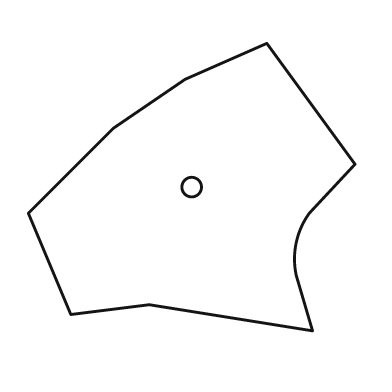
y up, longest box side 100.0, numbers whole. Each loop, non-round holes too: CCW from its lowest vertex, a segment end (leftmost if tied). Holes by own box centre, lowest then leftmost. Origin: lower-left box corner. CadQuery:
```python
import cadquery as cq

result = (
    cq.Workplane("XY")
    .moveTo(87.0, 0.0)
    .lineTo(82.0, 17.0)
    .threePointArc((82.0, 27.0), (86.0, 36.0))
    .lineTo(100.0, 51.0)
    .lineTo(73.0, 88.0)
    .lineTo(48.0, 77.0)
    .lineTo(26.0, 62.0)
    .lineTo(0.0, 36.0)
    .lineTo(13.0, 5.0)
    .lineTo(37.0, 8.0)
    .close()
    .moveTo(50.0, 44.0)
    .circle(3.0)
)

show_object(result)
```